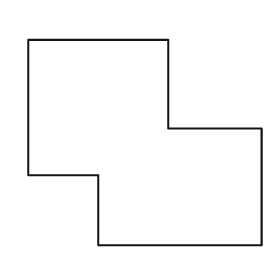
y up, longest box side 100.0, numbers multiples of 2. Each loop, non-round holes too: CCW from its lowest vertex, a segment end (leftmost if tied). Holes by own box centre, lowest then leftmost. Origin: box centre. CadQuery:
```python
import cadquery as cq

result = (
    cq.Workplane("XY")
    .moveTo(-20.0, -44.0)
    .lineTo(50.0, -44.0)
    .lineTo(50.0, 6.0)
    .lineTo(10.0, 6.0)
    .lineTo(10.0, 44.0)
    .lineTo(-50.0, 44.0)
    .lineTo(-50.0, -14.0)
    .lineTo(-20.0, -14.0)
    .close()
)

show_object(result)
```